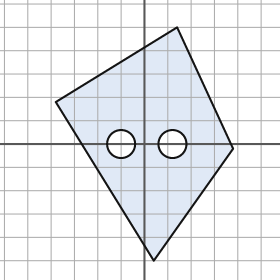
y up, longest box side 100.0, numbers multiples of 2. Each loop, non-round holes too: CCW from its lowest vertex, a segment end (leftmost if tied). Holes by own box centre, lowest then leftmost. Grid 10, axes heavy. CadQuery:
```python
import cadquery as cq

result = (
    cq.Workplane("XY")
    .moveTo(4.0, -50.0)
    .lineTo(38.0, -2.0)
    .lineTo(14.0, 50.0)
    .lineTo(-38.0, 18.0)
    .close()
    .moveTo(-10.0, 0.0)
    .circle(6.0)
    .moveTo(12.0, 0.0)
    .circle(6.0)
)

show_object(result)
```